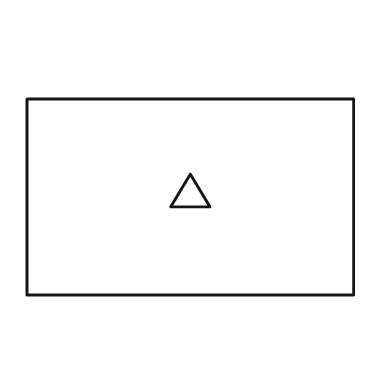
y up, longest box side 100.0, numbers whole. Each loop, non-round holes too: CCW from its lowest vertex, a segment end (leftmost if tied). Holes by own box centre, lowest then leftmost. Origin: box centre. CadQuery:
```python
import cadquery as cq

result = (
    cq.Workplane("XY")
    .moveTo(-50.0, -30.0)
    .lineTo(50.0, -30.0)
    .lineTo(50.0, 30.0)
    .lineTo(-50.0, 30.0)
    .close()
    .moveTo(-6.0, -3.0)
    .lineTo(6.0, -3.0)
    .lineTo(0.0, 7.0)
    .close()
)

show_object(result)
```